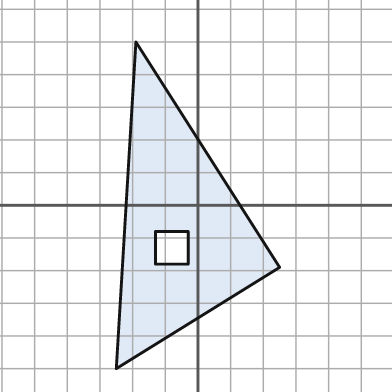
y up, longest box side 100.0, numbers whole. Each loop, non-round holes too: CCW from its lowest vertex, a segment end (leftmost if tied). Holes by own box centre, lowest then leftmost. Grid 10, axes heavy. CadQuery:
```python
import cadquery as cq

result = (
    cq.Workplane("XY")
    .moveTo(-25.0, -50.0)
    .lineTo(25.0, -19.0)
    .lineTo(-19.0, 50.0)
    .close()
    .moveTo(-13.0, -18.0)
    .lineTo(-3.0, -18.0)
    .lineTo(-3.0, -8.0)
    .lineTo(-13.0, -8.0)
    .close()
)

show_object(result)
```